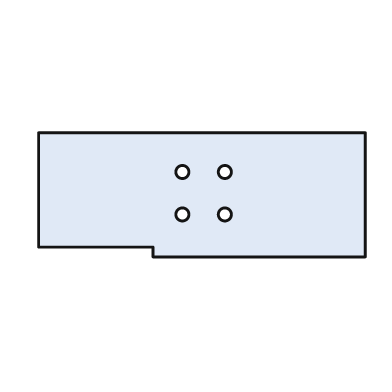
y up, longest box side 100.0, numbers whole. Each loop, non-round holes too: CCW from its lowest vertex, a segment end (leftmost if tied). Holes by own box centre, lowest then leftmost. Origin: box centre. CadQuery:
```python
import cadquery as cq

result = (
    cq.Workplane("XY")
    .moveTo(-15.0, -19.0)
    .lineTo(50.0, -19.0)
    .lineTo(50.0, 19.0)
    .lineTo(-50.0, 19.0)
    .lineTo(-50.0, -16.0)
    .lineTo(-15.0, -16.0)
    .close()
    .moveTo(-6.0, -6.0)
    .circle(2.0)
    .moveTo(7.0, -6.0)
    .circle(2.0)
    .moveTo(-6.0, 7.0)
    .circle(2.0)
    .moveTo(7.0, 7.0)
    .circle(2.0)
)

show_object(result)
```